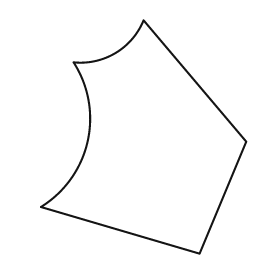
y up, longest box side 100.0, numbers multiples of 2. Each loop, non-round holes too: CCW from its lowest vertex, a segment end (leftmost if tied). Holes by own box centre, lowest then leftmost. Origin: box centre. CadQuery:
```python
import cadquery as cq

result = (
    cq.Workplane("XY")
    .moveTo(24.0, -50.0)
    .lineTo(44.0, -2.0)
    .lineTo(0.0, 50.0)
    .threePointArc((-12.0, 36.0), (-30.0, 32.0))
    .threePointArc((-24.0, -2.0), (-44.0, -30.0))
    .close()
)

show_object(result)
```